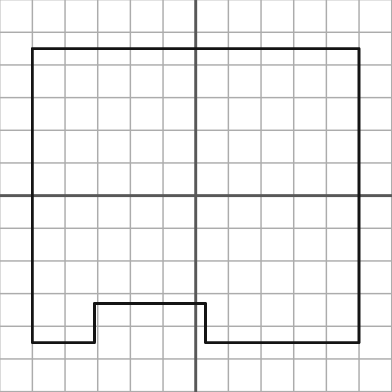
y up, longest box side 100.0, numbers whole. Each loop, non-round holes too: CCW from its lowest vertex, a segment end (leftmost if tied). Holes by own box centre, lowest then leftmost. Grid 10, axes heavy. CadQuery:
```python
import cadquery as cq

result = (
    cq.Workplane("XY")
    .moveTo(-50.0, -45.0)
    .lineTo(-31.0, -45.0)
    .lineTo(-31.0, -33.0)
    .lineTo(3.0, -33.0)
    .lineTo(3.0, -45.0)
    .lineTo(50.0, -45.0)
    .lineTo(50.0, 45.0)
    .lineTo(-50.0, 45.0)
    .close()
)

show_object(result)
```